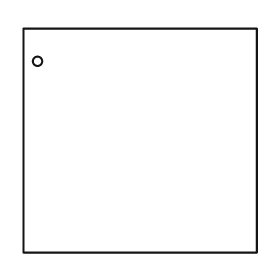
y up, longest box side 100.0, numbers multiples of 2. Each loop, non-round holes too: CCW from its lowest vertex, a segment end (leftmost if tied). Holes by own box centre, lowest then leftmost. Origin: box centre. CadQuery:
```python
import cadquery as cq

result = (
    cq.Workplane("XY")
    .moveTo(-50.0, -48.0)
    .lineTo(50.0, -48.0)
    .lineTo(50.0, 48.0)
    .lineTo(-50.0, 48.0)
    .close()
    .moveTo(-44.0, 34.0)
    .circle(2.0)
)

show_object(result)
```